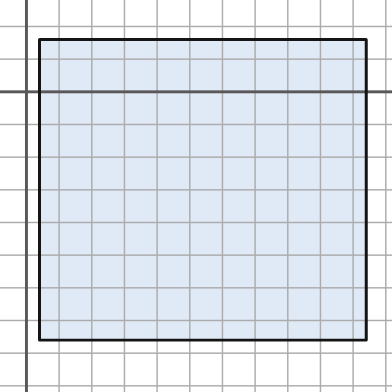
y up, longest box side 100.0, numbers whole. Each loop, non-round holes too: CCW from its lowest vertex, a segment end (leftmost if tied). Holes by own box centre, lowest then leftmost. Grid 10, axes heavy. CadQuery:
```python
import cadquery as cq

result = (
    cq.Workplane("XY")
    .moveTo(4.0, -76.0)
    .lineTo(104.0, -76.0)
    .lineTo(104.0, 16.0)
    .lineTo(4.0, 16.0)
    .close()
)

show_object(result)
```